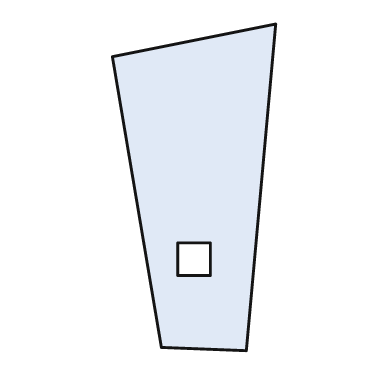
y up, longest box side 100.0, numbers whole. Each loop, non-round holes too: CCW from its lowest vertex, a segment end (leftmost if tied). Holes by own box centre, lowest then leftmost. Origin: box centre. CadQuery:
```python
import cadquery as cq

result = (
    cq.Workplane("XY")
    .moveTo(16.0, -50.0)
    .lineTo(25.0, 50.0)
    .lineTo(-25.0, 40.0)
    .lineTo(-10.0, -49.0)
    .close()
    .moveTo(-5.0, -27.0)
    .lineTo(5.0, -27.0)
    .lineTo(5.0, -17.0)
    .lineTo(-5.0, -17.0)
    .close()
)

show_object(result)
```